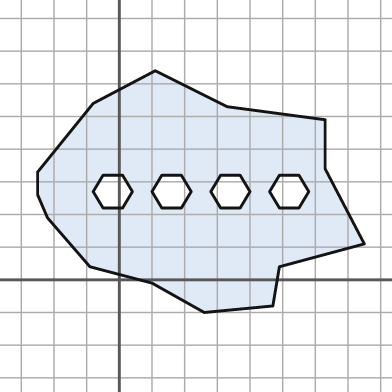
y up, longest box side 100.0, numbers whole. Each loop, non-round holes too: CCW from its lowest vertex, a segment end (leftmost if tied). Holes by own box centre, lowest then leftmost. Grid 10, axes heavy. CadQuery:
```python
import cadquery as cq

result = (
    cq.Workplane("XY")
    .moveTo(26.0, -10.0)
    .lineTo(47.0, -8.0)
    .lineTo(49.0, 4.0)
    .lineTo(75.0, 11.0)
    .lineTo(63.0, 34.0)
    .lineTo(63.0, 49.0)
    .lineTo(33.0, 53.0)
    .lineTo(11.0, 64.0)
    .lineTo(-8.0, 54.0)
    .lineTo(-25.0, 33.0)
    .lineTo(-25.0, 26.0)
    .lineTo(-22.0, 19.0)
    .lineTo(-9.0, 4.0)
    .lineTo(10.0, -1.0)
    .close()
    .moveTo(-5.0, 22.0)
    .lineTo(1.0, 22.0)
    .lineTo(4.0, 27.0)
    .lineTo(1.0, 32.0)
    .lineTo(-5.0, 32.0)
    .lineTo(-8.0, 27.0)
    .close()
    .moveTo(13.0, 22.0)
    .lineTo(19.0, 22.0)
    .lineTo(22.0, 27.0)
    .lineTo(19.0, 32.0)
    .lineTo(13.0, 32.0)
    .lineTo(10.0, 27.0)
    .close()
    .moveTo(31.0, 22.0)
    .lineTo(37.0, 22.0)
    .lineTo(40.0, 27.0)
    .lineTo(37.0, 32.0)
    .lineTo(31.0, 32.0)
    .lineTo(28.0, 27.0)
    .close()
    .moveTo(49.0, 22.0)
    .lineTo(55.0, 22.0)
    .lineTo(58.0, 27.0)
    .lineTo(55.0, 32.0)
    .lineTo(49.0, 32.0)
    .lineTo(46.0, 27.0)
    .close()
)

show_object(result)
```